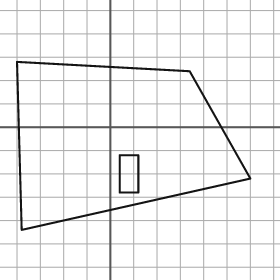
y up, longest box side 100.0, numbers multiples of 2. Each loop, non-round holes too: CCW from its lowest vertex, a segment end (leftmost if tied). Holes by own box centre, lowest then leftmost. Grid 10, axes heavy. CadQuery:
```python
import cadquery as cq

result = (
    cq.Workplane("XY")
    .moveTo(-38.0, -44.0)
    .lineTo(60.0, -22.0)
    .lineTo(34.0, 24.0)
    .lineTo(-40.0, 28.0)
    .close()
    .moveTo(4.0, -28.0)
    .lineTo(12.0, -28.0)
    .lineTo(12.0, -12.0)
    .lineTo(4.0, -12.0)
    .close()
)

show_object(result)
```